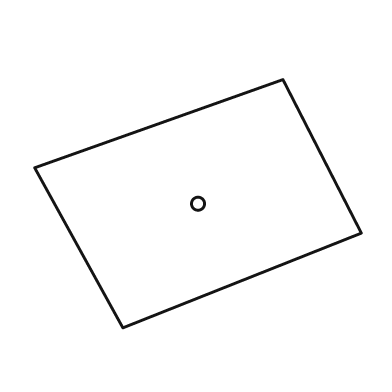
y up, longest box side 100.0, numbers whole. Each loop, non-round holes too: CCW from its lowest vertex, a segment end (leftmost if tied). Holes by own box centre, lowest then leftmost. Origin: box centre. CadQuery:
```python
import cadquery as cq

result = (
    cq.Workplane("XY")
    .moveTo(-23.0, -38.0)
    .lineTo(50.0, -9.0)
    .lineTo(26.0, 38.0)
    .lineTo(-50.0, 11.0)
    .close()
    .moveTo(0.0, 0.0)
    .circle(2.0)
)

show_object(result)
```